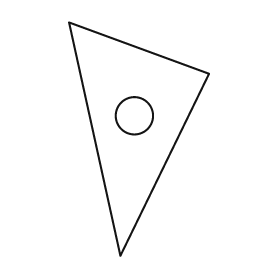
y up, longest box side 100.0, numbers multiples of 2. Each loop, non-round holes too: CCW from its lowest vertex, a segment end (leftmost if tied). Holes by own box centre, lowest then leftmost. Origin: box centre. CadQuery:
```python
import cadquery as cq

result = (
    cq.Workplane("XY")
    .moveTo(-8.0, -50.0)
    .lineTo(30.0, 28.0)
    .lineTo(-30.0, 50.0)
    .close()
    .moveTo(-2.0, 10.0)
    .circle(8.0)
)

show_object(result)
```